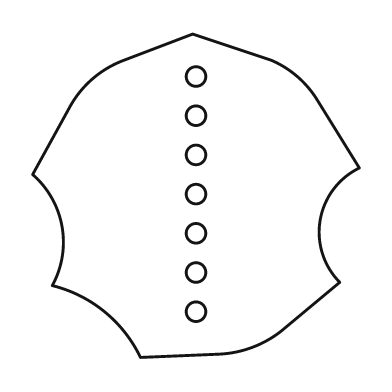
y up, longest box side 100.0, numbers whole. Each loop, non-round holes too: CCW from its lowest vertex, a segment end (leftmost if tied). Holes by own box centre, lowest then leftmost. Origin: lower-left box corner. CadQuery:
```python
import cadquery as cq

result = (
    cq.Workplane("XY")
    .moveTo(33.0, 0.0)
    .lineTo(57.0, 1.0)
    .threePointArc((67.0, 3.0), (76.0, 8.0))
    .lineTo(94.0, 23.0)
    .threePointArc((88.0, 42.0), (100.0, 58.0))
    .lineTo(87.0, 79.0)
    .threePointArc((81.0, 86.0), (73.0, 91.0))
    .lineTo(49.0, 99.0)
    .lineTo(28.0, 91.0)
    .threePointArc((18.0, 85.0), (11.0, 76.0))
    .lineTo(0.0, 56.0)
    .threePointArc((9.0, 40.0), (6.0, 22.0))
    .threePointArc((22.0, 14.0), (33.0, 0.0))
    .close()
    .moveTo(50.0, 14.0)
    .circle(3.0)
    .moveTo(50.0, 26.0)
    .circle(3.0)
    .moveTo(50.0, 38.0)
    .circle(3.0)
    .moveTo(50.0, 50.0)
    .circle(3.0)
    .moveTo(50.0, 62.0)
    .circle(3.0)
    .moveTo(50.0, 74.0)
    .circle(3.0)
    .moveTo(50.0, 86.0)
    .circle(3.0)
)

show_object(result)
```